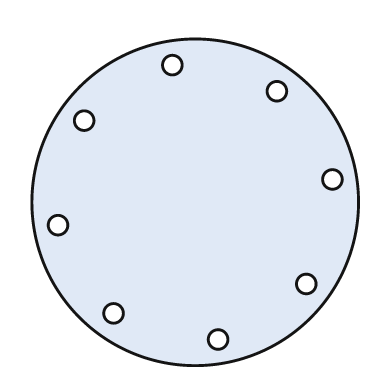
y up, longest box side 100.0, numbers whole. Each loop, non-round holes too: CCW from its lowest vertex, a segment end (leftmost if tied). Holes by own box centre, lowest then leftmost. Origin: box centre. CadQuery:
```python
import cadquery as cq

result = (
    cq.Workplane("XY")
    .moveTo(0.0, 0.0)
    .circle(50.0)
    .moveTo(7.0, -42.0)
    .circle(3.0)
    .moveTo(-25.0, -34.0)
    .circle(3.0)
    .moveTo(34.0, -25.0)
    .circle(3.0)
    .moveTo(-42.0, -7.0)
    .circle(3.0)
    .moveTo(42.0, 7.0)
    .circle(3.0)
    .moveTo(-34.0, 25.0)
    .circle(3.0)
    .moveTo(25.0, 34.0)
    .circle(3.0)
    .moveTo(-7.0, 42.0)
    .circle(3.0)
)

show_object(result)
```